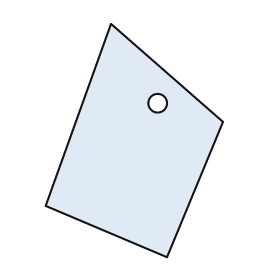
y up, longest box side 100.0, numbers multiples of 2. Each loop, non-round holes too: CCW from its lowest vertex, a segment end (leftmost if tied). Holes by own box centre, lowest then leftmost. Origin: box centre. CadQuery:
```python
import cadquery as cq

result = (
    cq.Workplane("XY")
    .moveTo(14.0, -50.0)
    .lineTo(38.0, 8.0)
    .lineTo(-10.0, 50.0)
    .lineTo(-38.0, -28.0)
    .close()
    .moveTo(10.0, 16.0)
    .circle(4.0)
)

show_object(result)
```